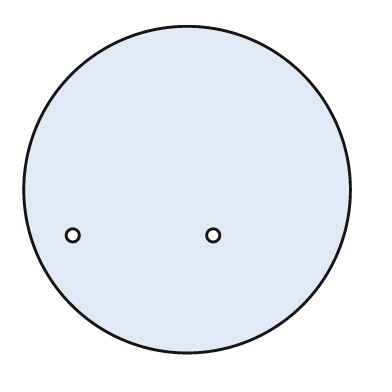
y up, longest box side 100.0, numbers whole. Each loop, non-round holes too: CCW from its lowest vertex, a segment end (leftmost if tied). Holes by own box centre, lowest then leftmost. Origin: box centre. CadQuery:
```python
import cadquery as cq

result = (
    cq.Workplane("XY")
    .moveTo(0.0, 0.0)
    .circle(50.0)
    .moveTo(-35.0, -14.0)
    .circle(2.0)
    .moveTo(8.0, -14.0)
    .circle(2.0)
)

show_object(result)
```